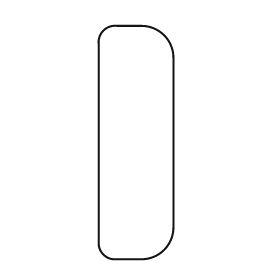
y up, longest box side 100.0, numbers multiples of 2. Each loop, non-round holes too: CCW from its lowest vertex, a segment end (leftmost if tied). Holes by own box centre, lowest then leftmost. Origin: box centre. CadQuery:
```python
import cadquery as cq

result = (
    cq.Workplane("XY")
    .moveTo(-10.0, -50.0)
    .lineTo(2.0, -50.0)
    .threePointArc((12.0, -46.0), (16.0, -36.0))
    .lineTo(16.0, 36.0)
    .threePointArc((12.0, 46.0), (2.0, 50.0))
    .lineTo(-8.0, 50.0)
    .threePointArc((-14.0, 48.0), (-16.0, 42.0))
    .lineTo(-16.0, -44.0)
    .threePointArc((-14.0, -48.0), (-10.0, -50.0))
    .close()
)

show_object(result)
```